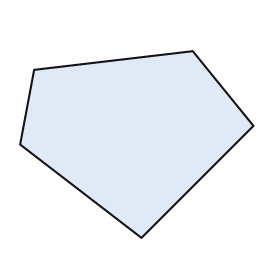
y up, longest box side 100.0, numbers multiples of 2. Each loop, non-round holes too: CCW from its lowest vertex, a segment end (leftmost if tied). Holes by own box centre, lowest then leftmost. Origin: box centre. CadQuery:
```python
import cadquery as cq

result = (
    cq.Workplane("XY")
    .moveTo(2.0, -40.0)
    .lineTo(50.0, 8.0)
    .lineTo(24.0, 40.0)
    .lineTo(-44.0, 32.0)
    .lineTo(-50.0, 0.0)
    .close()
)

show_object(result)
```